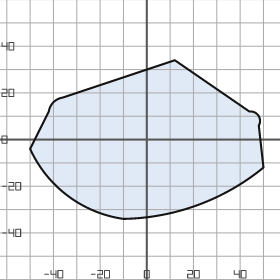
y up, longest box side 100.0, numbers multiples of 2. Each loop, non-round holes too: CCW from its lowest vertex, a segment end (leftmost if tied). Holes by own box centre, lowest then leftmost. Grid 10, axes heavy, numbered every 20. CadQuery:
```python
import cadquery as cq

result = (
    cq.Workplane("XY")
    .moveTo(-10.0, -34.0)
    .threePointArc((22.0, -28.0), (50.0, -12.0))
    .lineTo(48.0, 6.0)
    .threePointArc((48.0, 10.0), (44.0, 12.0))
    .lineTo(12.0, 34.0)
    .lineTo(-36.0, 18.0)
    .threePointArc((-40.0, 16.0), (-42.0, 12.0))
    .lineTo(-50.0, -4.0)
    .threePointArc((-34.0, -24.0), (-10.0, -34.0))
    .close()
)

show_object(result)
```